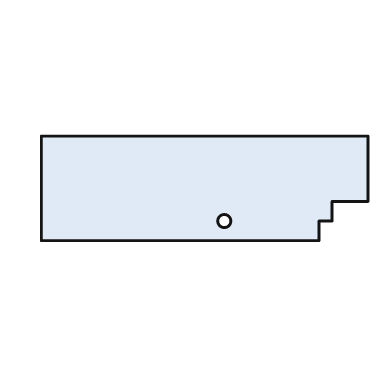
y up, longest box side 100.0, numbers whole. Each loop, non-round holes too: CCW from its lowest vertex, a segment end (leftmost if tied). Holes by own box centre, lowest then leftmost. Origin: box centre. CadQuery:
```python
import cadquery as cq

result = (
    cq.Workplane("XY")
    .moveTo(-50.0, -16.0)
    .lineTo(35.0, -16.0)
    .lineTo(35.0, -10.0)
    .lineTo(39.0, -10.0)
    .lineTo(39.0, -4.0)
    .lineTo(50.0, -4.0)
    .lineTo(50.0, 16.0)
    .lineTo(-50.0, 16.0)
    .close()
    .moveTo(6.0, -10.0)
    .circle(2.0)
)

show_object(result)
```